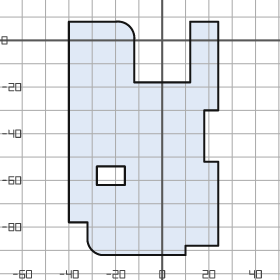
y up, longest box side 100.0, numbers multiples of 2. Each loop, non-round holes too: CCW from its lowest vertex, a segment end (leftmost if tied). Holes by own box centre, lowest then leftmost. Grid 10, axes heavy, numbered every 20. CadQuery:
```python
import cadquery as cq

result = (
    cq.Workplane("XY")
    .moveTo(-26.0, -92.0)
    .lineTo(10.0, -92.0)
    .lineTo(10.0, -88.0)
    .lineTo(24.0, -88.0)
    .lineTo(24.0, -52.0)
    .lineTo(18.0, -52.0)
    .lineTo(18.0, -30.0)
    .lineTo(24.0, -30.0)
    .lineTo(24.0, 8.0)
    .lineTo(12.0, 8.0)
    .lineTo(12.0, -18.0)
    .lineTo(-12.0, -18.0)
    .lineTo(-12.0, 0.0)
    .threePointArc((-14.0, 6.0), (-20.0, 8.0))
    .lineTo(-40.0, 8.0)
    .lineTo(-40.0, -78.0)
    .lineTo(-32.0, -78.0)
    .lineTo(-32.0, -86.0)
    .threePointArc((-30.0, -90.0), (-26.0, -92.0))
    .close()
    .moveTo(-28.0, -62.0)
    .lineTo(-16.0, -62.0)
    .lineTo(-16.0, -54.0)
    .lineTo(-28.0, -54.0)
    .close()
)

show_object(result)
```